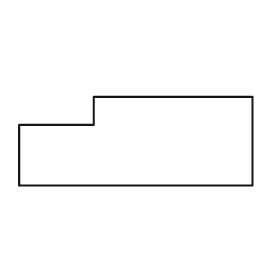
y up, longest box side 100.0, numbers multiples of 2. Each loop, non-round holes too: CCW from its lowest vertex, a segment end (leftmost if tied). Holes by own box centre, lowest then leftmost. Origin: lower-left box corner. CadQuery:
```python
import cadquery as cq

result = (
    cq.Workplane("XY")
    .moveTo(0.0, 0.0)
    .lineTo(100.0, 0.0)
    .lineTo(100.0, 38.0)
    .lineTo(32.0, 38.0)
    .lineTo(32.0, 26.0)
    .lineTo(0.0, 26.0)
    .close()
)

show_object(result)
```